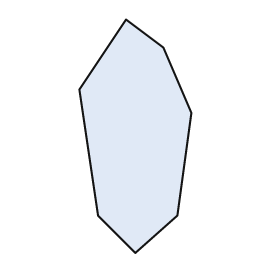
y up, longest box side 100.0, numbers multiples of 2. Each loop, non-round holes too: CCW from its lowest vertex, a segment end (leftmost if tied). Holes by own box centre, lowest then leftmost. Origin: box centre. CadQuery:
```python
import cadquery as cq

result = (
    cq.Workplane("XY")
    .moveTo(0.0, -50.0)
    .lineTo(18.0, -34.0)
    .lineTo(24.0, 10.0)
    .lineTo(12.0, 38.0)
    .lineTo(-4.0, 50.0)
    .lineTo(-24.0, 20.0)
    .lineTo(-16.0, -34.0)
    .close()
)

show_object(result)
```